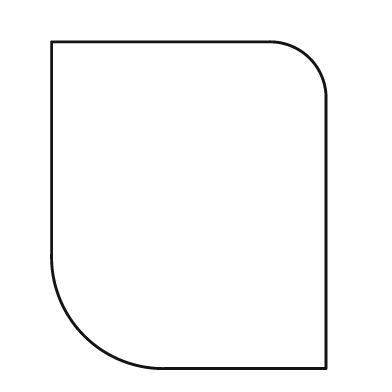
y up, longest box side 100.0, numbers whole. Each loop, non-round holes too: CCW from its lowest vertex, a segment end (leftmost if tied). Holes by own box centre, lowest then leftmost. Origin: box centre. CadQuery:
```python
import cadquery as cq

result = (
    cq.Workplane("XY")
    .moveTo(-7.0, -50.0)
    .lineTo(42.0, -50.0)
    .lineTo(42.0, 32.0)
    .threePointArc((37.0, 45.0), (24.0, 50.0))
    .lineTo(-42.0, 50.0)
    .lineTo(-42.0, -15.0)
    .threePointArc((-32.0, -40.0), (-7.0, -50.0))
    .close()
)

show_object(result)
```